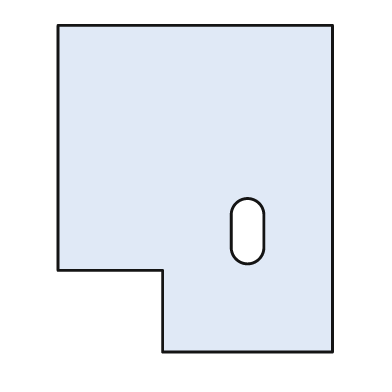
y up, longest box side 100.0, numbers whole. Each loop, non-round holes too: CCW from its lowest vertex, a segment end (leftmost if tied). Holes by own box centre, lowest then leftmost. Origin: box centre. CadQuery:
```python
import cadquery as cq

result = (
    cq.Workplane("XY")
    .moveTo(-10.0, -50.0)
    .lineTo(42.0, -50.0)
    .lineTo(42.0, 50.0)
    .lineTo(-42.0, 50.0)
    .lineTo(-42.0, -25.0)
    .lineTo(-10.0, -25.0)
    .close()
    .moveTo(11.0, -18.0)
    .threePointArc((16.0, -23.0), (21.0, -18.0))
    .lineTo(21.0, -8.0)
    .threePointArc((16.0, -3.0), (11.0, -8.0))
    .close()
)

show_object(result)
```